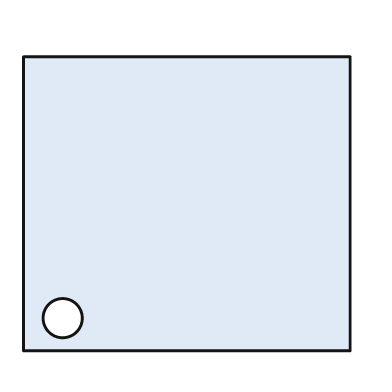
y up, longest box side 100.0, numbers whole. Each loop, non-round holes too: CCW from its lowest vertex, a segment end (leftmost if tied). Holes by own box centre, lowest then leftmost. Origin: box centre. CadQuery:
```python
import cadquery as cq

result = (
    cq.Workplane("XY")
    .moveTo(-50.0, -45.0)
    .lineTo(50.0, -45.0)
    .lineTo(50.0, 45.0)
    .lineTo(-50.0, 45.0)
    .close()
    .moveTo(-38.0, -35.0)
    .circle(6.0)
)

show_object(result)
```